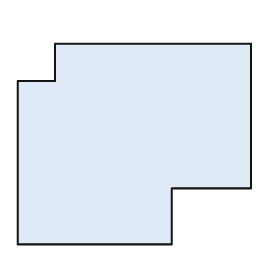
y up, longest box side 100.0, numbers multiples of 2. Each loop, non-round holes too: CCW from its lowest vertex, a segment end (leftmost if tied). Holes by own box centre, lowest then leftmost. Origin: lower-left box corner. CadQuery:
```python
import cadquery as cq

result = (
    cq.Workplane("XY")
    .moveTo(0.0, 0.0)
    .lineTo(66.0, 0.0)
    .lineTo(66.0, 24.0)
    .lineTo(100.0, 24.0)
    .lineTo(100.0, 86.0)
    .lineTo(16.0, 86.0)
    .lineTo(16.0, 70.0)
    .lineTo(0.0, 70.0)
    .close()
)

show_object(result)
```